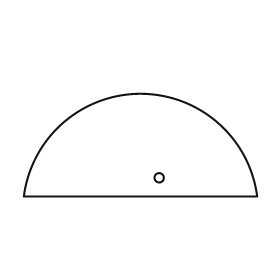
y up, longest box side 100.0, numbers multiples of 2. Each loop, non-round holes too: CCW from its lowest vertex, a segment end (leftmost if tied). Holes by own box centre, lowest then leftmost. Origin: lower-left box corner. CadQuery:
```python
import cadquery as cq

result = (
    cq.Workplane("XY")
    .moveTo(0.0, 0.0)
    .lineTo(100.0, 0.0)
    .threePointArc((50.0, 44.0), (0.0, 0.0))
    .close()
    .moveTo(58.0, 8.0)
    .circle(2.0)
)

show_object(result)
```